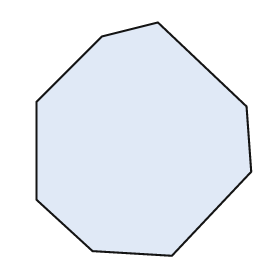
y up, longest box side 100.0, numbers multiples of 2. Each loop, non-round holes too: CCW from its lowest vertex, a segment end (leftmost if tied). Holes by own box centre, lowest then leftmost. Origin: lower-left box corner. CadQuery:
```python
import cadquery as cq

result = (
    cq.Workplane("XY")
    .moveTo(58.0, 0.0)
    .lineTo(92.0, 36.0)
    .lineTo(90.0, 64.0)
    .lineTo(52.0, 100.0)
    .lineTo(28.0, 94.0)
    .lineTo(0.0, 66.0)
    .lineTo(0.0, 24.0)
    .lineTo(24.0, 2.0)
    .close()
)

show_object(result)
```